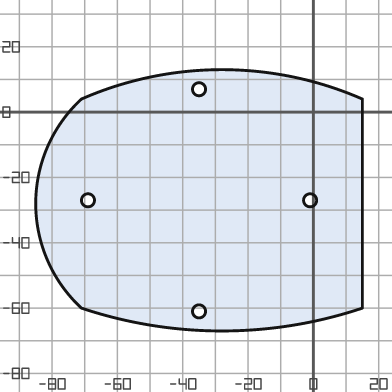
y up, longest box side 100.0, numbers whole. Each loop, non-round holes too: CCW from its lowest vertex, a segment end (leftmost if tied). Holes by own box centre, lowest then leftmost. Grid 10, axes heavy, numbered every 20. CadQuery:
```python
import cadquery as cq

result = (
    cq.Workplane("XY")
    .moveTo(-71.0, -60.0)
    .threePointArc((-28.0, -67.0), (15.0, -60.0))
    .lineTo(15.0, 4.0)
    .threePointArc((-28.0, 13.0), (-71.0, 4.0))
    .threePointArc((-85.0, -28.0), (-71.0, -60.0))
    .close()
    .moveTo(-35.0, -61.0)
    .circle(2.0)
    .moveTo(-69.0, -27.0)
    .circle(2.0)
    .moveTo(-1.0, -27.0)
    .circle(2.0)
    .moveTo(-35.0, 7.0)
    .circle(2.0)
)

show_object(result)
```